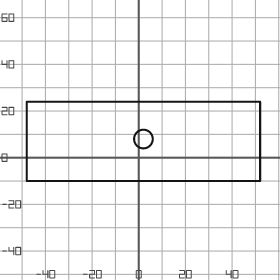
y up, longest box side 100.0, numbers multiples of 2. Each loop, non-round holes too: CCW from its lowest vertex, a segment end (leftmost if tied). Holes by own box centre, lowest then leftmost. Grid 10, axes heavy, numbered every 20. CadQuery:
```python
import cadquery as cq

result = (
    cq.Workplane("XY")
    .moveTo(-48.0, -10.0)
    .lineTo(52.0, -10.0)
    .lineTo(52.0, 24.0)
    .lineTo(-48.0, 24.0)
    .close()
    .moveTo(2.0, 8.0)
    .circle(4.0)
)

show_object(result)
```